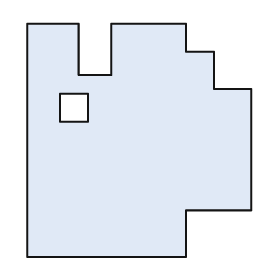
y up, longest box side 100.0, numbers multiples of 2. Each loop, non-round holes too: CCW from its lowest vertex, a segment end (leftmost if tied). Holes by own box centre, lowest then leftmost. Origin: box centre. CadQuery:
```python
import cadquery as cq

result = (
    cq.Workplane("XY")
    .moveTo(-48.0, -50.0)
    .lineTo(20.0, -50.0)
    .lineTo(20.0, -30.0)
    .lineTo(48.0, -30.0)
    .lineTo(48.0, 22.0)
    .lineTo(32.0, 22.0)
    .lineTo(32.0, 38.0)
    .lineTo(20.0, 38.0)
    .lineTo(20.0, 50.0)
    .lineTo(-12.0, 50.0)
    .lineTo(-12.0, 28.0)
    .lineTo(-26.0, 28.0)
    .lineTo(-26.0, 50.0)
    .lineTo(-48.0, 50.0)
    .close()
    .moveTo(-34.0, 8.0)
    .lineTo(-22.0, 8.0)
    .lineTo(-22.0, 20.0)
    .lineTo(-34.0, 20.0)
    .close()
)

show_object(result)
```